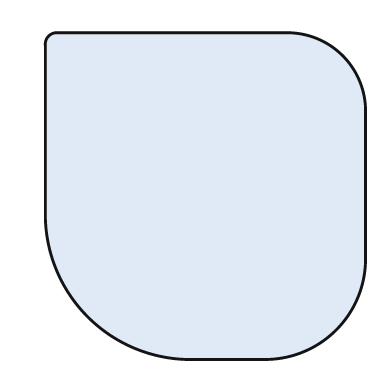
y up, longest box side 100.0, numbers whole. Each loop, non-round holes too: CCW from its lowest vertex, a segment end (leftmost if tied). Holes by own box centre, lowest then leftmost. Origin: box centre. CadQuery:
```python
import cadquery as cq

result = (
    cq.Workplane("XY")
    .moveTo(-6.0, -50.0)
    .lineTo(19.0, -50.0)
    .threePointArc((40.0, -41.0), (49.0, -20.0))
    .lineTo(49.0, 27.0)
    .threePointArc((42.0, 43.0), (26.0, 50.0))
    .lineTo(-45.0, 50.0)
    .threePointArc((-48.0, 49.0), (-49.0, 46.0))
    .lineTo(-49.0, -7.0)
    .threePointArc((-36.0, -37.0), (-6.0, -50.0))
    .close()
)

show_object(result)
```